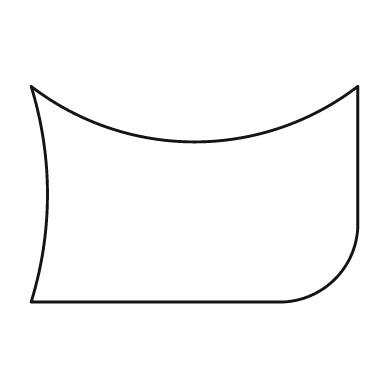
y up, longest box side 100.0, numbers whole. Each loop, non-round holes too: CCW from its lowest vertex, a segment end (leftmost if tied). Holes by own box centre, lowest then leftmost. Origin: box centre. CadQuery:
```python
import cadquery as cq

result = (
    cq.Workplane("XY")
    .moveTo(-50.0, -33.0)
    .lineTo(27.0, -33.0)
    .threePointArc((43.0, -26.0), (50.0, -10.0))
    .lineTo(50.0, 33.0)
    .threePointArc((0.0, 16.0), (-50.0, 33.0))
    .threePointArc((-45.0, 0.0), (-50.0, -33.0))
    .close()
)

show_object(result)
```